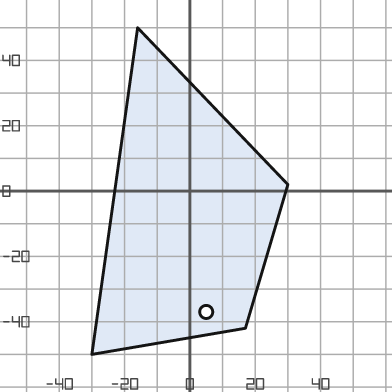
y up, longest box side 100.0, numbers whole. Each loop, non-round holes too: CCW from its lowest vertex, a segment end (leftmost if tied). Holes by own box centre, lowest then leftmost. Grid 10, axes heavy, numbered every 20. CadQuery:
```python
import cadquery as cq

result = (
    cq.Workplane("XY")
    .moveTo(-30.0, -50.0)
    .lineTo(17.0, -42.0)
    .lineTo(30.0, 2.0)
    .lineTo(-16.0, 50.0)
    .close()
    .moveTo(5.0, -37.0)
    .circle(2.0)
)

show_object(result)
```